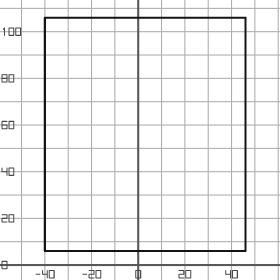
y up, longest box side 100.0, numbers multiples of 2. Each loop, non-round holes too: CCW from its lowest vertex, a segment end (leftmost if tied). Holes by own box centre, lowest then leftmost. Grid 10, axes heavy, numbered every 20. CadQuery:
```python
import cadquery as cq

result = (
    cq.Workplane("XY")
    .moveTo(-40.0, 6.0)
    .lineTo(46.0, 6.0)
    .lineTo(46.0, 106.0)
    .lineTo(-40.0, 106.0)
    .close()
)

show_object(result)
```